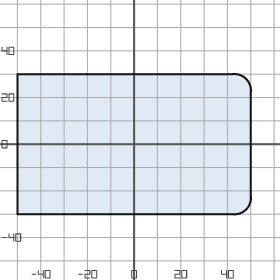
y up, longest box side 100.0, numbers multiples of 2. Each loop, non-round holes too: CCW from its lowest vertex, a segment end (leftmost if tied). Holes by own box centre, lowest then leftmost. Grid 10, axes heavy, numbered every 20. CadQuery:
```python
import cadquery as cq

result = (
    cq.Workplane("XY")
    .moveTo(-50.0, -30.0)
    .lineTo(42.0, -30.0)
    .threePointArc((48.0, -28.0), (50.0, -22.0))
    .lineTo(50.0, 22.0)
    .threePointArc((48.0, 28.0), (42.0, 30.0))
    .lineTo(-50.0, 30.0)
    .close()
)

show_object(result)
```